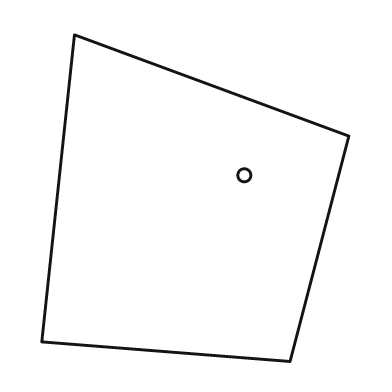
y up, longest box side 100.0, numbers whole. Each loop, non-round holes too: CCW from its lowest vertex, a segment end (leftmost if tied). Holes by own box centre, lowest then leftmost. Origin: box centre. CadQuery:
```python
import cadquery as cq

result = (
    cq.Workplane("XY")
    .moveTo(29.0, -50.0)
    .lineTo(47.0, 19.0)
    .lineTo(-37.0, 50.0)
    .lineTo(-47.0, -44.0)
    .close()
    .moveTo(15.0, 7.0)
    .circle(2.0)
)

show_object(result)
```